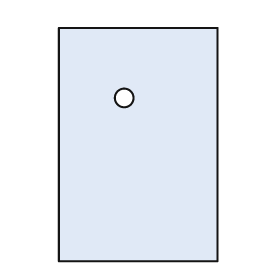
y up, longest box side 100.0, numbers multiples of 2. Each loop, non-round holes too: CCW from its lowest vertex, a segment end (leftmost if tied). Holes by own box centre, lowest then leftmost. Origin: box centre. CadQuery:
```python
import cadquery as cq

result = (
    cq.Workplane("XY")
    .moveTo(-34.0, -50.0)
    .lineTo(34.0, -50.0)
    .lineTo(34.0, 50.0)
    .lineTo(-34.0, 50.0)
    .close()
    .moveTo(-6.0, 20.0)
    .circle(4.0)
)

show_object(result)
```